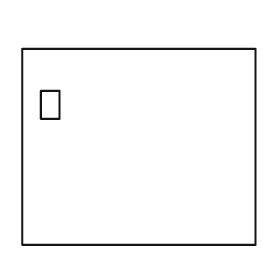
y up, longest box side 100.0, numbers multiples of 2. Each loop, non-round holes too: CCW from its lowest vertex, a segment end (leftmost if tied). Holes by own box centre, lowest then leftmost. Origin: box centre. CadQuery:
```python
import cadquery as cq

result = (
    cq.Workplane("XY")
    .moveTo(-50.0, -42.0)
    .lineTo(50.0, -42.0)
    .lineTo(50.0, 42.0)
    .lineTo(-50.0, 42.0)
    .close()
    .moveTo(-42.0, 12.0)
    .lineTo(-34.0, 12.0)
    .lineTo(-34.0, 24.0)
    .lineTo(-42.0, 24.0)
    .close()
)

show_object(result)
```